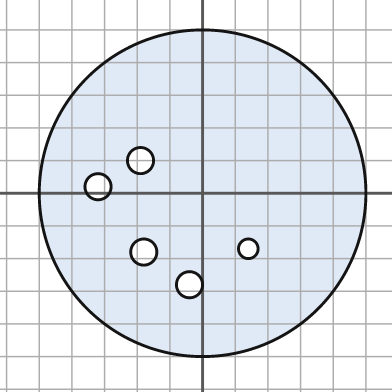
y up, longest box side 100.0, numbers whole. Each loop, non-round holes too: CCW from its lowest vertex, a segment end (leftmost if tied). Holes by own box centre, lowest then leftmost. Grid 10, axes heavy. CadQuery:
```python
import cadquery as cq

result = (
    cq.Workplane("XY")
    .moveTo(0.0, 0.0)
    .circle(50.0)
    .moveTo(-4.0, -28.0)
    .circle(4.0)
    .moveTo(-18.0, -18.0)
    .circle(4.0)
    .moveTo(14.0, -17.0)
    .circle(3.0)
    .moveTo(-32.0, 2.0)
    .circle(4.0)
    .moveTo(-19.0, 10.0)
    .circle(4.0)
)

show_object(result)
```